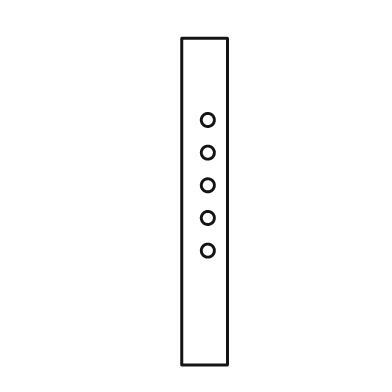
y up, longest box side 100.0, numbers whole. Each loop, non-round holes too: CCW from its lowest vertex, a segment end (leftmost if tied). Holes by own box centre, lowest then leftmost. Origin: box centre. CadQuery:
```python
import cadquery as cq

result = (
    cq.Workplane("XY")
    .moveTo(-7.0, -50.0)
    .lineTo(7.0, -50.0)
    .lineTo(7.0, 50.0)
    .lineTo(-7.0, 50.0)
    .close()
    .moveTo(1.0, -15.0)
    .circle(2.0)
    .moveTo(1.0, -5.0)
    .circle(2.0)
    .moveTo(1.0, 5.0)
    .circle(2.0)
    .moveTo(1.0, 15.0)
    .circle(2.0)
    .moveTo(1.0, 25.0)
    .circle(2.0)
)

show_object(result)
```